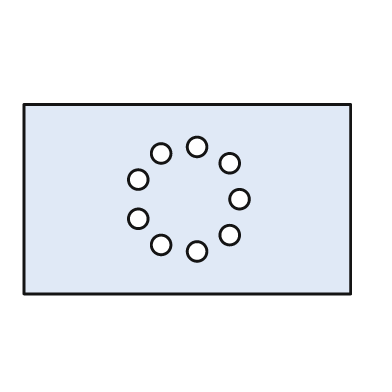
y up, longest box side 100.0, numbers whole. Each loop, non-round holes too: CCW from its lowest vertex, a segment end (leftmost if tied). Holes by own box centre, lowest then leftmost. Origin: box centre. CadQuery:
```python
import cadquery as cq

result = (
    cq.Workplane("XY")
    .moveTo(-50.0, -29.0)
    .lineTo(50.0, -29.0)
    .lineTo(50.0, 29.0)
    .lineTo(-50.0, 29.0)
    .close()
    .moveTo(3.0, -16.0)
    .circle(3.0)
    .moveTo(-8.0, -14.0)
    .circle(3.0)
    .moveTo(13.0, -11.0)
    .circle(3.0)
    .moveTo(-15.0, -6.0)
    .circle(3.0)
    .moveTo(16.0, 0.0)
    .circle(3.0)
    .moveTo(-15.0, 6.0)
    .circle(3.0)
    .moveTo(13.0, 11.0)
    .circle(3.0)
    .moveTo(-8.0, 14.0)
    .circle(3.0)
    .moveTo(3.0, 16.0)
    .circle(3.0)
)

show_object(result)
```